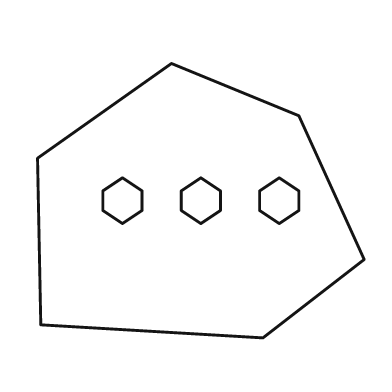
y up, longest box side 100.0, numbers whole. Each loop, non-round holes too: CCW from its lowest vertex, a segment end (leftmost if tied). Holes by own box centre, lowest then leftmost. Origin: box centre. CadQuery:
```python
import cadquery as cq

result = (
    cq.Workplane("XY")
    .moveTo(19.0, -42.0)
    .lineTo(50.0, -18.0)
    .lineTo(30.0, 26.0)
    .lineTo(-9.0, 42.0)
    .lineTo(-50.0, 13.0)
    .lineTo(-49.0, -38.0)
    .close()
    .moveTo(-24.0, -7.0)
    .lineTo(-18.0, -3.0)
    .lineTo(-18.0, 3.0)
    .lineTo(-24.0, 7.0)
    .lineTo(-30.0, 3.0)
    .lineTo(-30.0, -3.0)
    .close()
    .moveTo(0.0, -7.0)
    .lineTo(6.0, -3.0)
    .lineTo(6.0, 3.0)
    .lineTo(0.0, 7.0)
    .lineTo(-6.0, 3.0)
    .lineTo(-6.0, -3.0)
    .close()
    .moveTo(24.0, -7.0)
    .lineTo(30.0, -3.0)
    .lineTo(30.0, 3.0)
    .lineTo(24.0, 7.0)
    .lineTo(18.0, 3.0)
    .lineTo(18.0, -3.0)
    .close()
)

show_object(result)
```